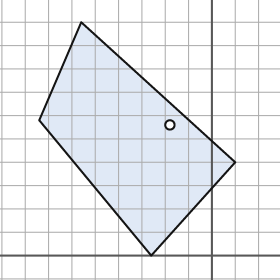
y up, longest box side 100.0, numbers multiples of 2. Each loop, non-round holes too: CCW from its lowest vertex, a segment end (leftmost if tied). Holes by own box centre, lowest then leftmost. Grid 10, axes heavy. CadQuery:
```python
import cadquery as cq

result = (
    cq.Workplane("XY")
    .moveTo(-26.0, 0.0)
    .lineTo(10.0, 40.0)
    .lineTo(-56.0, 100.0)
    .lineTo(-74.0, 58.0)
    .close()
    .moveTo(-18.0, 56.0)
    .circle(2.0)
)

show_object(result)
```